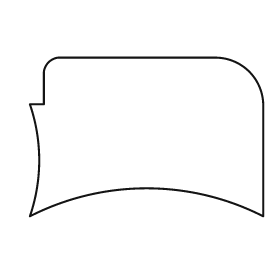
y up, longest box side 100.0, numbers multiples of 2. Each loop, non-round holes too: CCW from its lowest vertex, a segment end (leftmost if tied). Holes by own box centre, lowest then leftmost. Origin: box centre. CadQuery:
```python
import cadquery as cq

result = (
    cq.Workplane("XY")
    .moveTo(-50.0, -34.0)
    .threePointArc((0.0, -22.0), (50.0, -34.0))
    .lineTo(50.0, 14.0)
    .threePointArc((44.0, 28.0), (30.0, 34.0))
    .lineTo(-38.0, 34.0)
    .threePointArc((-42.0, 32.0), (-44.0, 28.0))
    .lineTo(-44.0, 14.0)
    .lineTo(-50.0, 14.0)
    .threePointArc((-46.0, -10.0), (-50.0, -34.0))
    .close()
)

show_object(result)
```